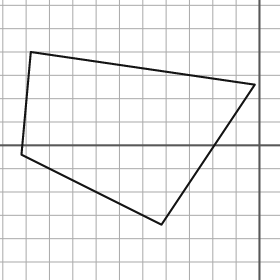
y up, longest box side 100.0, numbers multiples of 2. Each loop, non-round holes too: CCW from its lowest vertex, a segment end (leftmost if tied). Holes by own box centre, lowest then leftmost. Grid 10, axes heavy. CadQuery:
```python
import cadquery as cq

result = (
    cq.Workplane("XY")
    .moveTo(-42.0, -34.0)
    .lineTo(-2.0, 26.0)
    .lineTo(-98.0, 40.0)
    .lineTo(-102.0, -4.0)
    .close()
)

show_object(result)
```